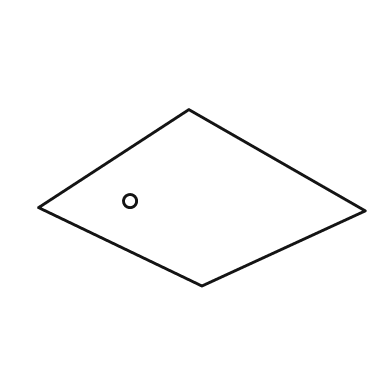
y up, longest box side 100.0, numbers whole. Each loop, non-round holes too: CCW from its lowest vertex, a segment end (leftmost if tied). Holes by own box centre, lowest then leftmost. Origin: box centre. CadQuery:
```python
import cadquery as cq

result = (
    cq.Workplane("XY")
    .moveTo(0.0, -27.0)
    .lineTo(50.0, -4.0)
    .lineTo(-4.0, 27.0)
    .lineTo(-50.0, -3.0)
    .close()
    .moveTo(-22.0, -1.0)
    .circle(2.0)
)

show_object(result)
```